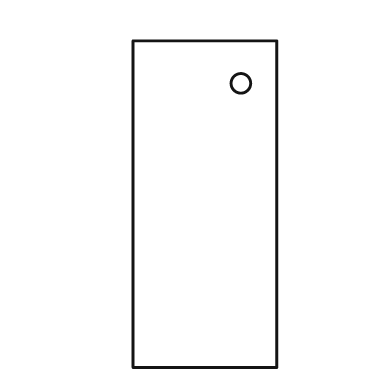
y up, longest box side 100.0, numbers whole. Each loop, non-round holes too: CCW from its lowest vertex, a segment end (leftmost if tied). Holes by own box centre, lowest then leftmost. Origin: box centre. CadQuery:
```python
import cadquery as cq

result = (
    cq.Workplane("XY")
    .moveTo(-22.0, -50.0)
    .lineTo(22.0, -50.0)
    .lineTo(22.0, 50.0)
    .lineTo(-22.0, 50.0)
    .close()
    .moveTo(11.0, 37.0)
    .circle(3.0)
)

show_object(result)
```